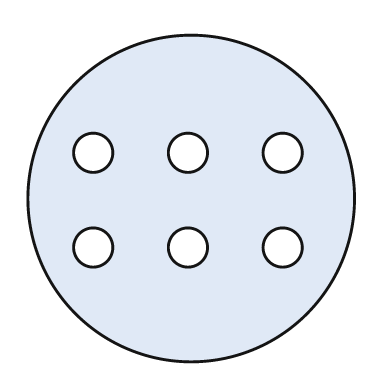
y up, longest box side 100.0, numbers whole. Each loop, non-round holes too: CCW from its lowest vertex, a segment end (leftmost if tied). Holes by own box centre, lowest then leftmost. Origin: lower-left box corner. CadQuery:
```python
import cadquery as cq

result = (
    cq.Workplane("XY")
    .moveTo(50.0, 50.0)
    .circle(50.0)
    .moveTo(20.0, 35.0)
    .circle(6.0)
    .moveTo(49.0, 35.0)
    .circle(6.0)
    .moveTo(78.0, 35.0)
    .circle(6.0)
    .moveTo(20.0, 64.0)
    .circle(6.0)
    .moveTo(49.0, 64.0)
    .circle(6.0)
    .moveTo(78.0, 64.0)
    .circle(6.0)
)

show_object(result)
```